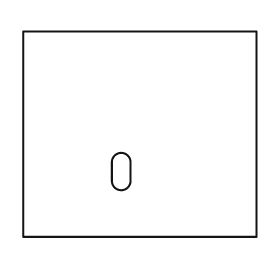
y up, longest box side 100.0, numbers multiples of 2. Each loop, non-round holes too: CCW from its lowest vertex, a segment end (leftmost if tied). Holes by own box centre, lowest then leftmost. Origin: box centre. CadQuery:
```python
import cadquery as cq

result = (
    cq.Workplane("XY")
    .moveTo(-50.0, -44.0)
    .lineTo(50.0, -44.0)
    .lineTo(50.0, 44.0)
    .lineTo(-50.0, 44.0)
    .close()
    .moveTo(-12.0, -20.0)
    .threePointArc((-8.0, -24.0), (-4.0, -20.0))
    .lineTo(-4.0, -12.0)
    .threePointArc((-8.0, -8.0), (-12.0, -12.0))
    .close()
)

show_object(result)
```